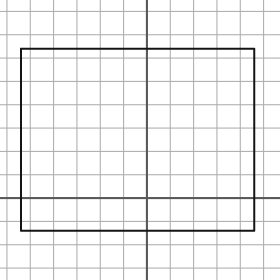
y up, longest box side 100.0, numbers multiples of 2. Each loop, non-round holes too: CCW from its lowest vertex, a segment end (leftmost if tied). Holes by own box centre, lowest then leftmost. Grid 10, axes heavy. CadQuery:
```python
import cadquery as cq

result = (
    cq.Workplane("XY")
    .moveTo(-54.0, -14.0)
    .lineTo(46.0, -14.0)
    .lineTo(46.0, 64.0)
    .lineTo(-54.0, 64.0)
    .close()
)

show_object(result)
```